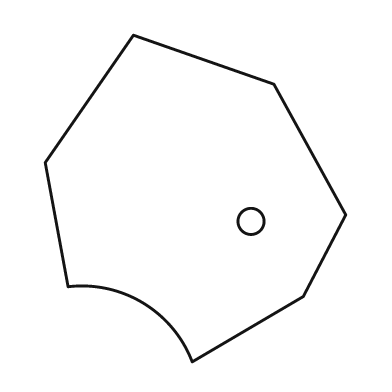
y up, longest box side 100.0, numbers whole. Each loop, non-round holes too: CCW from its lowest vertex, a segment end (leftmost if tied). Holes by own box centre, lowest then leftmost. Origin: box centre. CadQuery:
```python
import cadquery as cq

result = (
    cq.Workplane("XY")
    .moveTo(-1.0, -50.0)
    .lineTo(33.0, -30.0)
    .lineTo(46.0, -5.0)
    .lineTo(24.0, 35.0)
    .lineTo(-19.0, 50.0)
    .lineTo(-46.0, 11.0)
    .lineTo(-39.0, -27.0)
    .threePointArc((-16.0, -32.0), (-1.0, -50.0))
    .close()
    .moveTo(17.0, -7.0)
    .circle(4.0)
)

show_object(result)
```